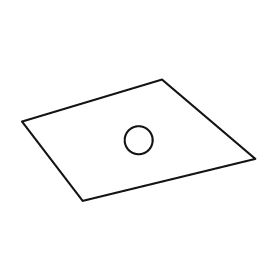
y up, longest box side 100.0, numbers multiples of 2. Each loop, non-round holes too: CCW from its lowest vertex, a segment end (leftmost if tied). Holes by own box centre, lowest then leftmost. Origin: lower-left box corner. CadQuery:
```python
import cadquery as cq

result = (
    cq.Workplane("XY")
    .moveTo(26.0, 0.0)
    .lineTo(100.0, 18.0)
    .lineTo(60.0, 52.0)
    .lineTo(0.0, 34.0)
    .close()
    .moveTo(50.0, 26.0)
    .circle(6.0)
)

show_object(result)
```